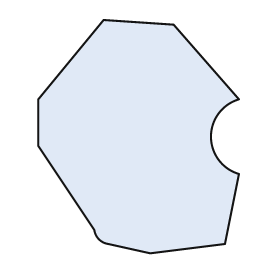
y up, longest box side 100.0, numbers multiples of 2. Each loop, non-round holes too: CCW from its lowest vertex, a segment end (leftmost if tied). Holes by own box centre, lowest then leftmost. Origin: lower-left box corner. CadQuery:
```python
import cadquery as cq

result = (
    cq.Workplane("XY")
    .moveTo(48.0, 0.0)
    .lineTo(80.0, 4.0)
    .lineTo(86.0, 34.0)
    .threePointArc((74.0, 50.0), (86.0, 66.0))
    .lineTo(58.0, 98.0)
    .lineTo(28.0, 100.0)
    .lineTo(0.0, 66.0)
    .lineTo(0.0, 46.0)
    .lineTo(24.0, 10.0)
    .threePointArc((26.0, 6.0), (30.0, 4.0))
    .close()
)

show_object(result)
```